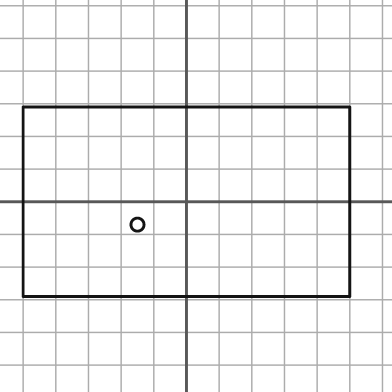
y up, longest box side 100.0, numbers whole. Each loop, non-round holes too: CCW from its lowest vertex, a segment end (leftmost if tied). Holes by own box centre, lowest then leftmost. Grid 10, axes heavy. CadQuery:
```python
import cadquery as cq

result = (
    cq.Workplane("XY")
    .moveTo(-50.0, -29.0)
    .lineTo(50.0, -29.0)
    .lineTo(50.0, 29.0)
    .lineTo(-50.0, 29.0)
    .close()
    .moveTo(-15.0, -7.0)
    .circle(2.0)
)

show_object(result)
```